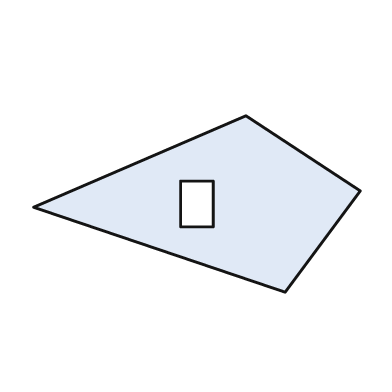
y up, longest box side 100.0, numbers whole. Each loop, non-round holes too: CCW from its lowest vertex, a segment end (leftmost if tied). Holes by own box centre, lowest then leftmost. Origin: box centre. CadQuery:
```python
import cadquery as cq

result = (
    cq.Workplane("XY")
    .moveTo(27.0, -27.0)
    .lineTo(50.0, 4.0)
    .lineTo(15.0, 27.0)
    .lineTo(-50.0, -1.0)
    .close()
    .moveTo(-5.0, -7.0)
    .lineTo(5.0, -7.0)
    .lineTo(5.0, 7.0)
    .lineTo(-5.0, 7.0)
    .close()
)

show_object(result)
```